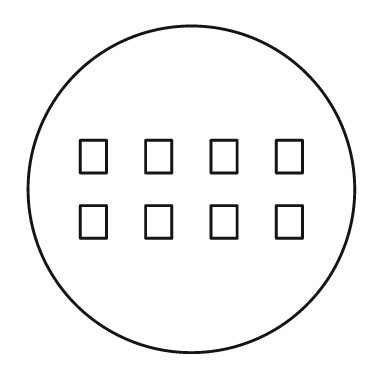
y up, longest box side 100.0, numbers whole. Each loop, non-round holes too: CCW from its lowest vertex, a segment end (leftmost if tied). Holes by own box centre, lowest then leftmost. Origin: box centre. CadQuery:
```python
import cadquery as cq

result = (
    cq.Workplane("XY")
    .moveTo(0.0, 0.0)
    .circle(50.0)
    .moveTo(-34.0, -15.0)
    .lineTo(-26.0, -15.0)
    .lineTo(-26.0, -5.0)
    .lineTo(-34.0, -5.0)
    .close()
    .moveTo(-14.0, -15.0)
    .lineTo(-6.0, -15.0)
    .lineTo(-6.0, -5.0)
    .lineTo(-14.0, -5.0)
    .close()
    .moveTo(6.0, -15.0)
    .lineTo(14.0, -15.0)
    .lineTo(14.0, -5.0)
    .lineTo(6.0, -5.0)
    .close()
    .moveTo(26.0, -15.0)
    .lineTo(34.0, -15.0)
    .lineTo(34.0, -5.0)
    .lineTo(26.0, -5.0)
    .close()
    .moveTo(-34.0, 5.0)
    .lineTo(-26.0, 5.0)
    .lineTo(-26.0, 15.0)
    .lineTo(-34.0, 15.0)
    .close()
    .moveTo(-14.0, 5.0)
    .lineTo(-6.0, 5.0)
    .lineTo(-6.0, 15.0)
    .lineTo(-14.0, 15.0)
    .close()
    .moveTo(6.0, 5.0)
    .lineTo(14.0, 5.0)
    .lineTo(14.0, 15.0)
    .lineTo(6.0, 15.0)
    .close()
    .moveTo(26.0, 5.0)
    .lineTo(34.0, 5.0)
    .lineTo(34.0, 15.0)
    .lineTo(26.0, 15.0)
    .close()
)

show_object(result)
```